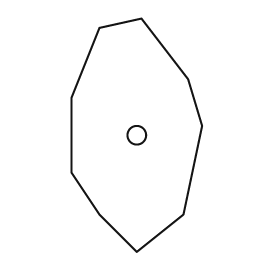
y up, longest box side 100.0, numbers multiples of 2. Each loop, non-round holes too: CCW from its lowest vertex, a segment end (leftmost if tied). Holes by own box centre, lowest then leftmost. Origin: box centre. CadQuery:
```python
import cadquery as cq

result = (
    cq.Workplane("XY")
    .moveTo(0.0, -50.0)
    .lineTo(20.0, -34.0)
    .lineTo(28.0, 4.0)
    .lineTo(22.0, 24.0)
    .lineTo(2.0, 50.0)
    .lineTo(-16.0, 46.0)
    .lineTo(-28.0, 16.0)
    .lineTo(-28.0, -16.0)
    .lineTo(-16.0, -34.0)
    .close()
    .moveTo(0.0, 0.0)
    .circle(4.0)
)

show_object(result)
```